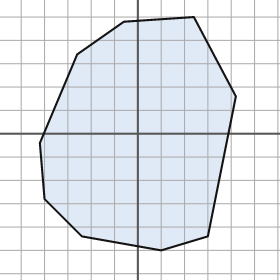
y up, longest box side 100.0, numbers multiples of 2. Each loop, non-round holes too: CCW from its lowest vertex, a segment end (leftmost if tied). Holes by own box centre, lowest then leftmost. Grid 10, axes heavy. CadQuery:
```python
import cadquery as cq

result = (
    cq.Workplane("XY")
    .moveTo(10.0, -50.0)
    .lineTo(30.0, -44.0)
    .lineTo(42.0, 16.0)
    .lineTo(24.0, 50.0)
    .lineTo(-6.0, 48.0)
    .lineTo(-26.0, 34.0)
    .lineTo(-42.0, -4.0)
    .lineTo(-40.0, -28.0)
    .lineTo(-24.0, -44.0)
    .close()
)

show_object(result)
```